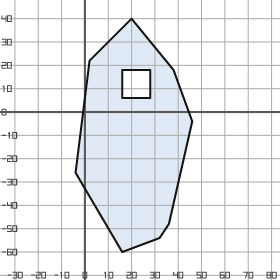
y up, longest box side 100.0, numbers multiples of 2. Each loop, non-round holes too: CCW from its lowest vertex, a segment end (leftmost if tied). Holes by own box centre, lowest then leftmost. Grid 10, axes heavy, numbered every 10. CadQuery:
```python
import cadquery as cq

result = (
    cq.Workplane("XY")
    .moveTo(16.0, -60.0)
    .lineTo(32.0, -54.0)
    .lineTo(36.0, -48.0)
    .lineTo(46.0, -4.0)
    .lineTo(38.0, 18.0)
    .lineTo(20.0, 40.0)
    .lineTo(2.0, 22.0)
    .lineTo(-4.0, -26.0)
    .close()
    .moveTo(16.0, 6.0)
    .lineTo(28.0, 6.0)
    .lineTo(28.0, 18.0)
    .lineTo(16.0, 18.0)
    .close()
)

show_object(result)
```